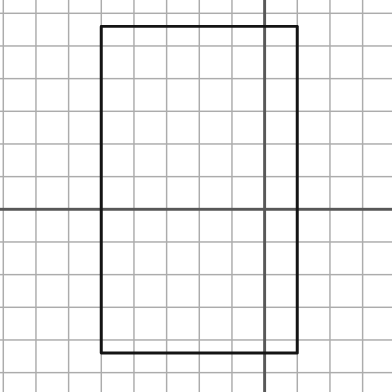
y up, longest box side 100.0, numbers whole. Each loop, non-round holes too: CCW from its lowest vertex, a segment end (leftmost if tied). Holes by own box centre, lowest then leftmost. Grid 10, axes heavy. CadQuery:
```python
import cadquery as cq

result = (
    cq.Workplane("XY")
    .moveTo(-50.0, -44.0)
    .lineTo(10.0, -44.0)
    .lineTo(10.0, 56.0)
    .lineTo(-50.0, 56.0)
    .close()
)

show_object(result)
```